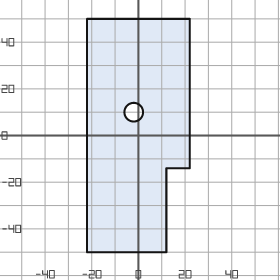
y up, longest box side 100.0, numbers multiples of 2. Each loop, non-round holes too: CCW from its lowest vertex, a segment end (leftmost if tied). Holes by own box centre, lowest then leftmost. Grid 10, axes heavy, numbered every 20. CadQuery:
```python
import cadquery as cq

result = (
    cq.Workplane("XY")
    .moveTo(-22.0, -50.0)
    .lineTo(12.0, -50.0)
    .lineTo(12.0, -14.0)
    .lineTo(22.0, -14.0)
    .lineTo(22.0, 50.0)
    .lineTo(-22.0, 50.0)
    .close()
    .moveTo(-2.0, 10.0)
    .circle(4.0)
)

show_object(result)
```